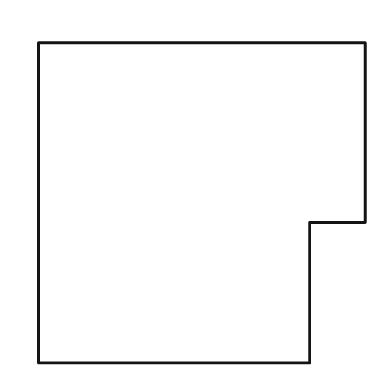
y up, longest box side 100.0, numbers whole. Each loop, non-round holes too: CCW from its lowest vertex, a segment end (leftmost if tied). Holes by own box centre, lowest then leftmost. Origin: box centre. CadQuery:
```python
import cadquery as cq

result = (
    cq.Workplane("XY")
    .moveTo(-50.0, -49.0)
    .lineTo(33.0, -49.0)
    .lineTo(33.0, -6.0)
    .lineTo(50.0, -6.0)
    .lineTo(50.0, 49.0)
    .lineTo(-50.0, 49.0)
    .close()
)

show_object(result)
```